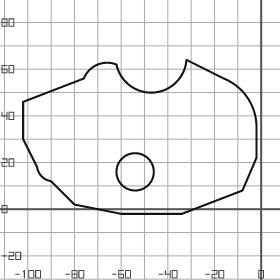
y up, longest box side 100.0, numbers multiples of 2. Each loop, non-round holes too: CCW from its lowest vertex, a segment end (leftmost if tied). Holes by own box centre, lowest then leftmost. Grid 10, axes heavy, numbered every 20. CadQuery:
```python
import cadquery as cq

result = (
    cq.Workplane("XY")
    .moveTo(-60.0, -2.0)
    .lineTo(-34.0, -2.0)
    .lineTo(-8.0, 8.0)
    .lineTo(-2.0, 22.0)
    .lineTo(-2.0, 36.0)
    .threePointArc((-6.0, 48.0), (-16.0, 56.0))
    .lineTo(-32.0, 64.0)
    .threePointArc((-46.0, 50.0), (-62.0, 62.0))
    .threePointArc((-70.0, 62.0), (-76.0, 56.0))
    .lineTo(-102.0, 46.0)
    .lineTo(-102.0, 30.0)
    .lineTo(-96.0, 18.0)
    .threePointArc((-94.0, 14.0), (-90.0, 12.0))
    .lineTo(-80.0, 2.0)
    .close()
    .moveTo(-54.0, 16.0)
    .circle(8.0)
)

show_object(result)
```